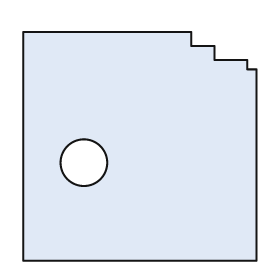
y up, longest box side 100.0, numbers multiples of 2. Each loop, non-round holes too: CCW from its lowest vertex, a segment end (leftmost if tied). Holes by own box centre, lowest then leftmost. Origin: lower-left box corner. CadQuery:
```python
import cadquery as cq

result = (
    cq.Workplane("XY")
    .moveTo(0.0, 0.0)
    .lineTo(100.0, 0.0)
    .lineTo(100.0, 82.0)
    .lineTo(96.0, 82.0)
    .lineTo(96.0, 86.0)
    .lineTo(82.0, 86.0)
    .lineTo(82.0, 92.0)
    .lineTo(72.0, 92.0)
    .lineTo(72.0, 98.0)
    .lineTo(0.0, 98.0)
    .close()
    .moveTo(26.0, 42.0)
    .circle(10.0)
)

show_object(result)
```